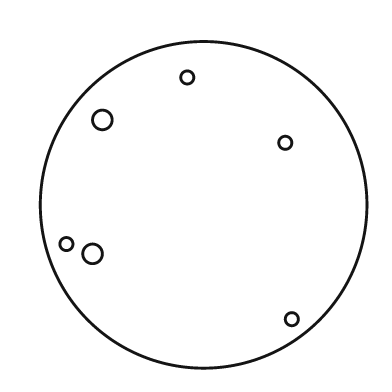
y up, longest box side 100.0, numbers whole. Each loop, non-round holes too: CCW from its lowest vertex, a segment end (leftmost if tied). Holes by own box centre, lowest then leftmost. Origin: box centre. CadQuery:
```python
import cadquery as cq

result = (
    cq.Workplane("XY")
    .moveTo(0.0, 0.0)
    .circle(50.0)
    .moveTo(27.0, -35.0)
    .circle(2.0)
    .moveTo(-34.0, -15.0)
    .circle(3.0)
    .moveTo(-42.0, -12.0)
    .circle(2.0)
    .moveTo(25.0, 19.0)
    .circle(2.0)
    .moveTo(-31.0, 26.0)
    .circle(3.0)
    .moveTo(-5.0, 39.0)
    .circle(2.0)
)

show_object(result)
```